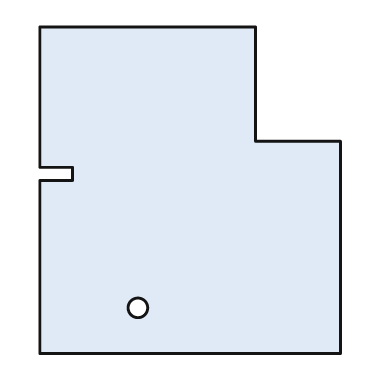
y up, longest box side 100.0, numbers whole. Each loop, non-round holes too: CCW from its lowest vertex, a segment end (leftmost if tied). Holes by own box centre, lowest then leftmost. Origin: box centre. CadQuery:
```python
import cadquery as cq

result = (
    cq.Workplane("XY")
    .moveTo(-46.0, -50.0)
    .lineTo(46.0, -50.0)
    .lineTo(46.0, 15.0)
    .lineTo(20.0, 15.0)
    .lineTo(20.0, 50.0)
    .lineTo(-46.0, 50.0)
    .lineTo(-46.0, 7.0)
    .lineTo(-36.0, 7.0)
    .lineTo(-36.0, 3.0)
    .lineTo(-46.0, 3.0)
    .close()
    .moveTo(-16.0, -36.0)
    .circle(3.0)
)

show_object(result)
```